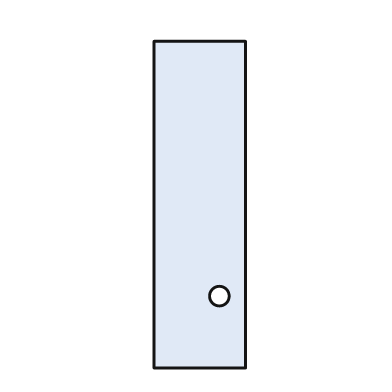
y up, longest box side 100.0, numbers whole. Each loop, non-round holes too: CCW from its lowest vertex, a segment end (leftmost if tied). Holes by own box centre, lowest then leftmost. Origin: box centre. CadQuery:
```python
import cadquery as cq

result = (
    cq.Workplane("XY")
    .moveTo(-14.0, -50.0)
    .lineTo(14.0, -50.0)
    .lineTo(14.0, 50.0)
    .lineTo(-14.0, 50.0)
    .close()
    .moveTo(6.0, -28.0)
    .circle(3.0)
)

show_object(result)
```